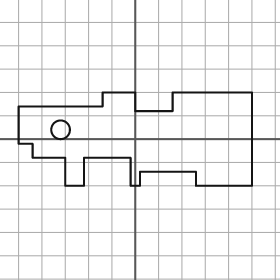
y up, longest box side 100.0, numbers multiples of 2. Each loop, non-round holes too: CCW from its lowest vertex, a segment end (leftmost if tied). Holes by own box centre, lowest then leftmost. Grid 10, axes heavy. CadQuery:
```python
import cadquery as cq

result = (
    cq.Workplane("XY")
    .moveTo(-30.0, -20.0)
    .lineTo(-22.0, -20.0)
    .lineTo(-22.0, -8.0)
    .lineTo(-2.0, -8.0)
    .lineTo(-2.0, -20.0)
    .lineTo(2.0, -20.0)
    .lineTo(2.0, -14.0)
    .lineTo(26.0, -14.0)
    .lineTo(26.0, -20.0)
    .lineTo(50.0, -20.0)
    .lineTo(50.0, 20.0)
    .lineTo(16.0, 20.0)
    .lineTo(16.0, 12.0)
    .lineTo(0.0, 12.0)
    .lineTo(0.0, 20.0)
    .lineTo(-14.0, 20.0)
    .lineTo(-14.0, 14.0)
    .lineTo(-50.0, 14.0)
    .lineTo(-50.0, -2.0)
    .lineTo(-44.0, -2.0)
    .lineTo(-44.0, -8.0)
    .lineTo(-30.0, -8.0)
    .close()
    .moveTo(-32.0, 4.0)
    .circle(4.0)
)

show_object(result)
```